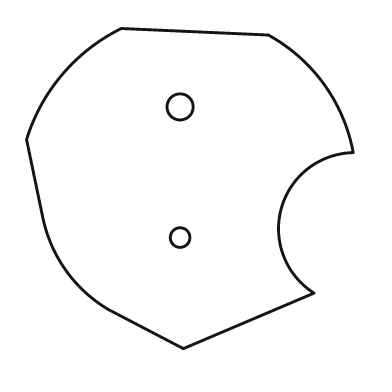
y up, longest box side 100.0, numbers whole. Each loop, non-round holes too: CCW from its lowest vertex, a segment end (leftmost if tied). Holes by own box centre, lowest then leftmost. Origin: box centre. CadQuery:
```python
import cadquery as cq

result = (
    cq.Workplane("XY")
    .moveTo(-2.0, -49.0)
    .lineTo(38.0, -32.0)
    .threePointArc((28.0, -6.0), (50.0, 11.0))
    .threePointArc((41.0, 32.0), (24.0, 47.0))
    .lineTo(-21.0, 49.0)
    .threePointArc((-39.0, 35.0), (-50.0, 15.0))
    .lineTo(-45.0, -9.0)
    .threePointArc((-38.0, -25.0), (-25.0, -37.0))
    .close()
    .moveTo(-3.0, -15.0)
    .circle(3.0)
    .moveTo(-3.0, 25.0)
    .circle(4.0)
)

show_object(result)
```